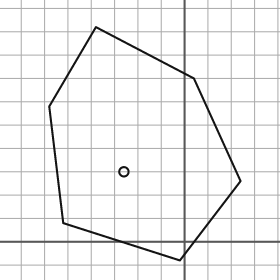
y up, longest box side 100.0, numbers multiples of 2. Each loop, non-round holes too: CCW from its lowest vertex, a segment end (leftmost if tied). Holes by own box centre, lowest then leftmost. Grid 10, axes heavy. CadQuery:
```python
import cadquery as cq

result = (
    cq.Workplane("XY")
    .moveTo(-2.0, -8.0)
    .lineTo(24.0, 26.0)
    .lineTo(4.0, 70.0)
    .lineTo(-38.0, 92.0)
    .lineTo(-58.0, 58.0)
    .lineTo(-52.0, 8.0)
    .close()
    .moveTo(-26.0, 30.0)
    .circle(2.0)
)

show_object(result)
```